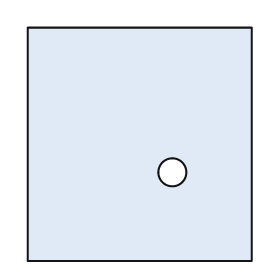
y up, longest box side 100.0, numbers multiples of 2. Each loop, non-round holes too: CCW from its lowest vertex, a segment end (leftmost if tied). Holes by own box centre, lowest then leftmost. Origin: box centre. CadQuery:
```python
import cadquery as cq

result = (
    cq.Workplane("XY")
    .moveTo(-48.0, -50.0)
    .lineTo(48.0, -50.0)
    .lineTo(48.0, 50.0)
    .lineTo(-48.0, 50.0)
    .close()
    .moveTo(14.0, -12.0)
    .circle(6.0)
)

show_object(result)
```